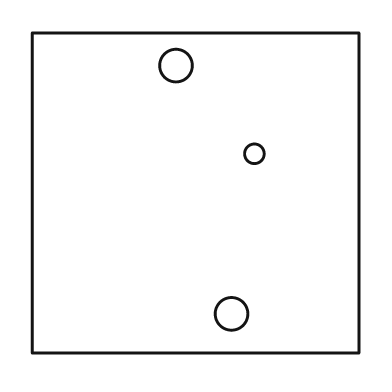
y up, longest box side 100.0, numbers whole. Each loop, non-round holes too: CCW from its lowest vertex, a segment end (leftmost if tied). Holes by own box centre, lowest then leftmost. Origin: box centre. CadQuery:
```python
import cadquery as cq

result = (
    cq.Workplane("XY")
    .moveTo(-50.0, -49.0)
    .lineTo(50.0, -49.0)
    .lineTo(50.0, 49.0)
    .lineTo(-50.0, 49.0)
    .close()
    .moveTo(11.0, -37.0)
    .circle(5.0)
    .moveTo(18.0, 12.0)
    .circle(3.0)
    .moveTo(-6.0, 39.0)
    .circle(5.0)
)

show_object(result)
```